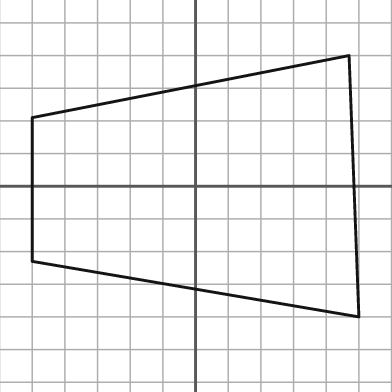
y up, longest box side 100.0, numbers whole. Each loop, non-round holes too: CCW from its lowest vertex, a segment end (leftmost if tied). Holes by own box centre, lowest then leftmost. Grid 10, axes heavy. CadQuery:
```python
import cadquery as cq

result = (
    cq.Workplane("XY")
    .moveTo(50.0, -40.0)
    .lineTo(47.0, 40.0)
    .lineTo(-50.0, 21.0)
    .lineTo(-50.0, -23.0)
    .close()
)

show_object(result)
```